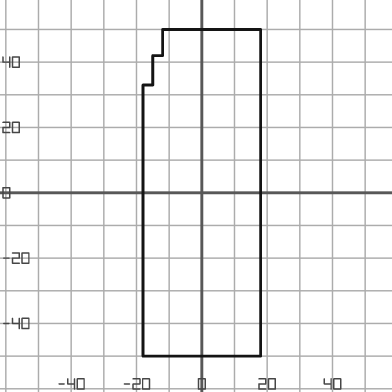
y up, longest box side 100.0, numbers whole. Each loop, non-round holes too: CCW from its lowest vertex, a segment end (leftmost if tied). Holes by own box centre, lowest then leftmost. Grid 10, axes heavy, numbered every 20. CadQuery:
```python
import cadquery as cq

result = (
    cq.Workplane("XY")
    .moveTo(-18.0, -50.0)
    .lineTo(18.0, -50.0)
    .lineTo(18.0, 50.0)
    .lineTo(-12.0, 50.0)
    .lineTo(-12.0, 42.0)
    .lineTo(-15.0, 42.0)
    .lineTo(-15.0, 33.0)
    .lineTo(-18.0, 33.0)
    .close()
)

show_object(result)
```